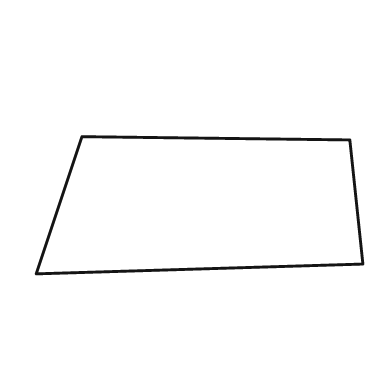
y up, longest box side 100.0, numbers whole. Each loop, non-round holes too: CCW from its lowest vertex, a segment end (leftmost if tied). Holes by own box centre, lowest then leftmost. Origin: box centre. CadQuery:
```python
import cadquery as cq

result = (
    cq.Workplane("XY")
    .moveTo(-50.0, -21.0)
    .lineTo(50.0, -18.0)
    .lineTo(46.0, 20.0)
    .lineTo(-36.0, 21.0)
    .close()
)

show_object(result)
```